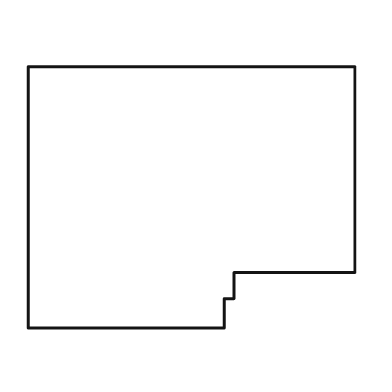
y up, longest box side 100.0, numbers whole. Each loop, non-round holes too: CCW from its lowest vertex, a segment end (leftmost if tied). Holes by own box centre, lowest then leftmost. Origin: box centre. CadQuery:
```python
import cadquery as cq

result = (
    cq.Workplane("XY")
    .moveTo(-50.0, -40.0)
    .lineTo(10.0, -40.0)
    .lineTo(10.0, -31.0)
    .lineTo(13.0, -31.0)
    .lineTo(13.0, -23.0)
    .lineTo(50.0, -23.0)
    .lineTo(50.0, 40.0)
    .lineTo(-50.0, 40.0)
    .close()
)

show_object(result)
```